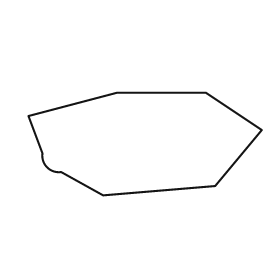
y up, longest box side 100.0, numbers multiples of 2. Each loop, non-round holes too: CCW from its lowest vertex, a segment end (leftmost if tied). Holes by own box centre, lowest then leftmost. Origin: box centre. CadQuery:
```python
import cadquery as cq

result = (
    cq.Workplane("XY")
    .moveTo(-18.0, -22.0)
    .lineTo(30.0, -18.0)
    .lineTo(50.0, 6.0)
    .lineTo(26.0, 22.0)
    .lineTo(-12.0, 22.0)
    .lineTo(-50.0, 12.0)
    .lineTo(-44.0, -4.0)
    .threePointArc((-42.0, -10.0), (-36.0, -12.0))
    .close()
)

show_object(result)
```